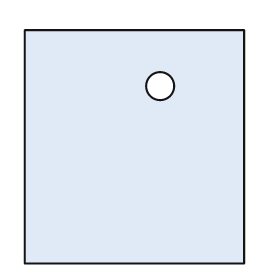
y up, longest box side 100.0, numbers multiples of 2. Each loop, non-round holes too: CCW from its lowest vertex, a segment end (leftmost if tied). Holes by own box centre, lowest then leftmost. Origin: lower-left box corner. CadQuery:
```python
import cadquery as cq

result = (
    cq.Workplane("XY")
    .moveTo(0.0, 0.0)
    .lineTo(94.0, 0.0)
    .lineTo(94.0, 100.0)
    .lineTo(0.0, 100.0)
    .close()
    .moveTo(58.0, 76.0)
    .circle(6.0)
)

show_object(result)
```